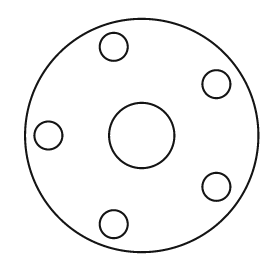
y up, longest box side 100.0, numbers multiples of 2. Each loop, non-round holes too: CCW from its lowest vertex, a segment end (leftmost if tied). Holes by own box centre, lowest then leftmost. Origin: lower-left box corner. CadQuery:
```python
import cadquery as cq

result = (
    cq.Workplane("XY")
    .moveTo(50.0, 50.0)
    .circle(50.0)
    .moveTo(38.0, 12.0)
    .circle(6.0)
    .moveTo(82.0, 28.0)
    .circle(6.0)
    .moveTo(10.0, 50.0)
    .circle(6.0)
    .moveTo(50.0, 50.0)
    .circle(14.0)
    .moveTo(82.0, 72.0)
    .circle(6.0)
    .moveTo(38.0, 88.0)
    .circle(6.0)
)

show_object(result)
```